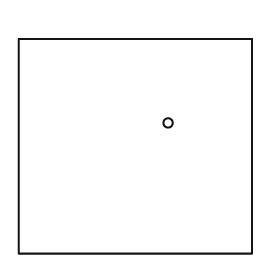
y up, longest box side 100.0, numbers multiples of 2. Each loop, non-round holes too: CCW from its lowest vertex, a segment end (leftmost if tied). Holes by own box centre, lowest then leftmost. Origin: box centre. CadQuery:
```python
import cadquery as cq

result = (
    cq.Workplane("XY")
    .moveTo(-50.0, -46.0)
    .lineTo(50.0, -46.0)
    .lineTo(50.0, 46.0)
    .lineTo(-50.0, 46.0)
    .close()
    .moveTo(14.0, 10.0)
    .circle(2.0)
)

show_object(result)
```